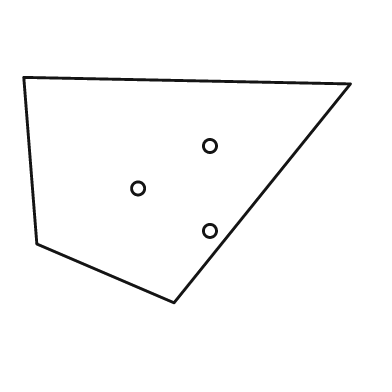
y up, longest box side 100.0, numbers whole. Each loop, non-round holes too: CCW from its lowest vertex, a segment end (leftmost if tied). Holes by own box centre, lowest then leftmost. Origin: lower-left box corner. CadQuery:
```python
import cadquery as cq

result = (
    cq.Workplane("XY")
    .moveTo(46.0, 0.0)
    .lineTo(100.0, 67.0)
    .lineTo(0.0, 69.0)
    .lineTo(4.0, 18.0)
    .close()
    .moveTo(57.0, 22.0)
    .circle(2.0)
    .moveTo(35.0, 35.0)
    .circle(2.0)
    .moveTo(57.0, 48.0)
    .circle(2.0)
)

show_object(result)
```